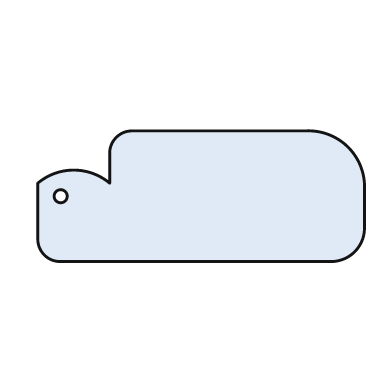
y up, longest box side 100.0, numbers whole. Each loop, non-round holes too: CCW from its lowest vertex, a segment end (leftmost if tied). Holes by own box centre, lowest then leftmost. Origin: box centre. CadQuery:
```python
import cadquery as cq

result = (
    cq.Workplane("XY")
    .moveTo(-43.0, -20.0)
    .lineTo(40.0, -20.0)
    .threePointArc((47.0, -17.0), (50.0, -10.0))
    .lineTo(50.0, 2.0)
    .threePointArc((45.0, 15.0), (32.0, 20.0))
    .lineTo(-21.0, 20.0)
    .threePointArc((-26.0, 18.0), (-28.0, 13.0))
    .lineTo(-28.0, 4.0)
    .threePointArc((-39.0, 8.0), (-50.0, 4.0))
    .lineTo(-50.0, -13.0)
    .threePointArc((-48.0, -18.0), (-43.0, -20.0))
    .close()
    .moveTo(-43.0, 0.0)
    .circle(2.0)
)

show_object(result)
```